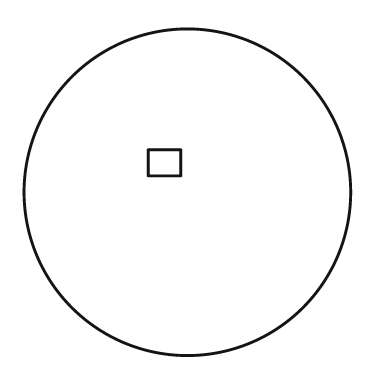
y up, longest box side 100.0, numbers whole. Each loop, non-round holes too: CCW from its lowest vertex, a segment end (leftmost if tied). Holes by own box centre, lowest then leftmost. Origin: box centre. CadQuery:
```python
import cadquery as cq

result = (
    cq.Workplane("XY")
    .moveTo(0.0, 0.0)
    .circle(50.0)
    .moveTo(-12.0, 5.0)
    .lineTo(-2.0, 5.0)
    .lineTo(-2.0, 13.0)
    .lineTo(-12.0, 13.0)
    .close()
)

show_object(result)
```